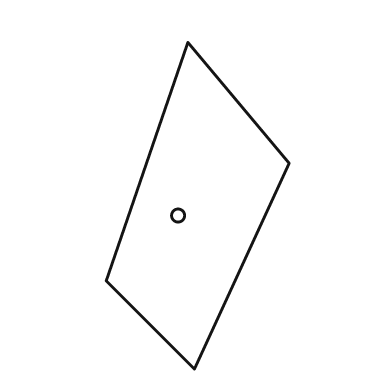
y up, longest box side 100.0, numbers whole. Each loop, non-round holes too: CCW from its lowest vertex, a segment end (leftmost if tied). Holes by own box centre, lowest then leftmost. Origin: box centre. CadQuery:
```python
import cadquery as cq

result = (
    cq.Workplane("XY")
    .moveTo(-1.0, -50.0)
    .lineTo(28.0, 13.0)
    .lineTo(-3.0, 50.0)
    .lineTo(-28.0, -23.0)
    .close()
    .moveTo(-6.0, -3.0)
    .circle(2.0)
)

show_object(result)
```